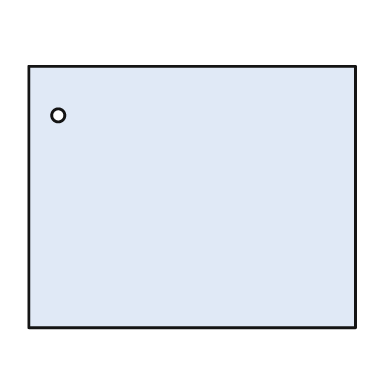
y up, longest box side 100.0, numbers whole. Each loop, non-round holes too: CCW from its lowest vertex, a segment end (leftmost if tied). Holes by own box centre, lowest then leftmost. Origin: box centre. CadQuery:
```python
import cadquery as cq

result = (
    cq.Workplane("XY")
    .moveTo(-50.0, -40.0)
    .lineTo(50.0, -40.0)
    .lineTo(50.0, 40.0)
    .lineTo(-50.0, 40.0)
    .close()
    .moveTo(-41.0, 25.0)
    .circle(2.0)
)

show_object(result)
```